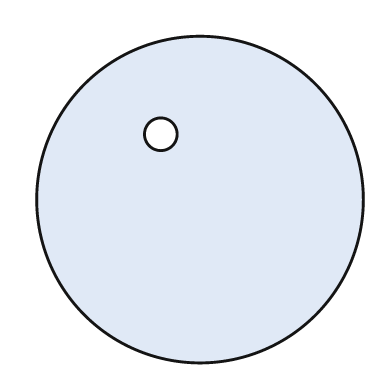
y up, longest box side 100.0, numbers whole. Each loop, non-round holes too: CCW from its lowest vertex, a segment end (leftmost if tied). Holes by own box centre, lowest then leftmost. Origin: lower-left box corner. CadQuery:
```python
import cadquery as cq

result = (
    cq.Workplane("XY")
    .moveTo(50.0, 50.0)
    .circle(50.0)
    .moveTo(38.0, 70.0)
    .circle(5.0)
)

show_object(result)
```